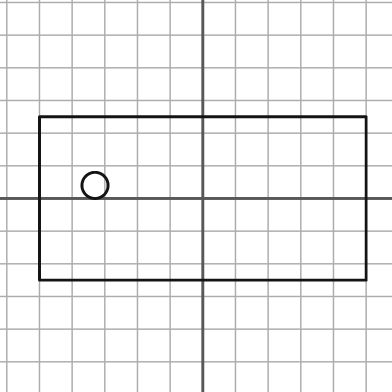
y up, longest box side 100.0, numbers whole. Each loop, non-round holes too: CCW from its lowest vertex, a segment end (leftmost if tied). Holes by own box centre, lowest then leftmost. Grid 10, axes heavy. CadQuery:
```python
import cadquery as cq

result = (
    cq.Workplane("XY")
    .moveTo(-50.0, -25.0)
    .lineTo(50.0, -25.0)
    .lineTo(50.0, 25.0)
    .lineTo(-50.0, 25.0)
    .close()
    .moveTo(-33.0, 4.0)
    .circle(4.0)
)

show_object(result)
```